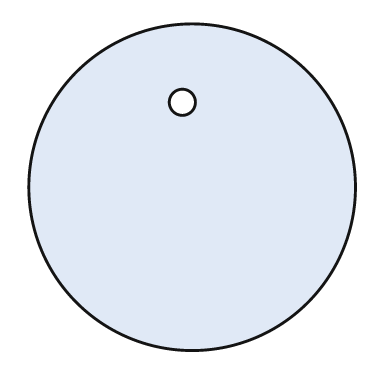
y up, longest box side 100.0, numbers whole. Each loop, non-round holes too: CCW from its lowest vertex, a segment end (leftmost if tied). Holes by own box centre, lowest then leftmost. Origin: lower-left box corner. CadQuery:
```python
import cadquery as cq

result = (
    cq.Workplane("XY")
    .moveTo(50.0, 50.0)
    .circle(50.0)
    .moveTo(47.0, 76.0)
    .circle(4.0)
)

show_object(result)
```